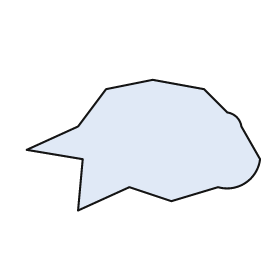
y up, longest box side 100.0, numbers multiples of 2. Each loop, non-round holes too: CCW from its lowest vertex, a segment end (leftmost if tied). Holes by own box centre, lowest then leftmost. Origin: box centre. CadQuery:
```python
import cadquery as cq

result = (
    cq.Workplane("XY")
    .moveTo(-28.0, -28.0)
    .lineTo(-6.0, -18.0)
    .lineTo(12.0, -24.0)
    .lineTo(32.0, -18.0)
    .threePointArc((44.0, -16.0), (50.0, -6.0))
    .lineTo(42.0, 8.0)
    .threePointArc((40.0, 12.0), (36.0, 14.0))
    .lineTo(26.0, 24.0)
    .lineTo(4.0, 28.0)
    .lineTo(-16.0, 24.0)
    .lineTo(-28.0, 8.0)
    .lineTo(-50.0, -2.0)
    .lineTo(-26.0, -6.0)
    .close()
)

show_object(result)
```